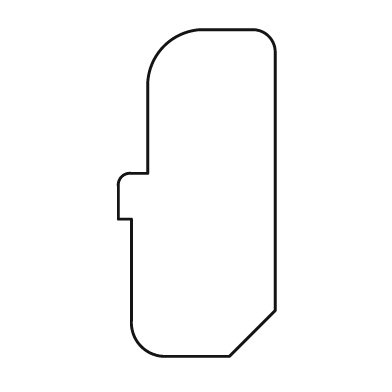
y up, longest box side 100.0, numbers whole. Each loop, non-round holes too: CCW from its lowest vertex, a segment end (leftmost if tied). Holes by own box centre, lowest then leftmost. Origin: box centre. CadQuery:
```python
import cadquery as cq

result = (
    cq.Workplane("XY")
    .moveTo(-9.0, -50.0)
    .lineTo(10.0, -50.0)
    .lineTo(24.0, -36.0)
    .lineTo(24.0, 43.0)
    .threePointArc((22.0, 48.0), (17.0, 50.0))
    .lineTo(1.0, 50.0)
    .threePointArc((-10.0, 45.0), (-15.0, 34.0))
    .lineTo(-15.0, 6.0)
    .lineTo(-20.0, 6.0)
    .threePointArc((-23.0, 5.0), (-24.0, 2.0))
    .lineTo(-24.0, -8.0)
    .lineTo(-20.0, -8.0)
    .lineTo(-20.0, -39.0)
    .threePointArc((-17.0, -47.0), (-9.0, -50.0))
    .close()
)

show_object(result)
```